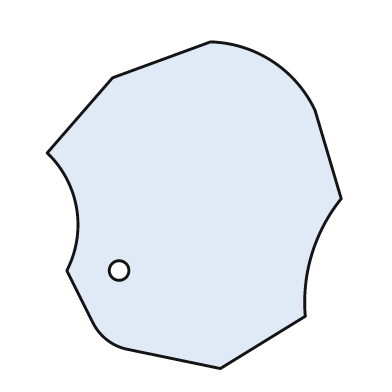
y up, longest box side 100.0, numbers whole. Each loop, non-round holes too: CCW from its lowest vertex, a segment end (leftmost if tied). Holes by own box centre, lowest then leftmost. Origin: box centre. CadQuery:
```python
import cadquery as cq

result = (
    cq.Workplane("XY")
    .moveTo(8.0, -50.0)
    .lineTo(34.0, -34.0)
    .threePointArc((36.0, -15.0), (45.0, 2.0))
    .lineTo(37.0, 29.0)
    .threePointArc((24.0, 44.0), (5.0, 50.0))
    .lineTo(-25.0, 39.0)
    .lineTo(-45.0, 16.0)
    .threePointArc((-36.0, -1.0), (-39.0, -20.0))
    .lineTo(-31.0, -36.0)
    .threePointArc((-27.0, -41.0), (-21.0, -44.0))
    .close()
    .moveTo(-23.0, -20.0)
    .circle(3.0)
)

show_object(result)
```